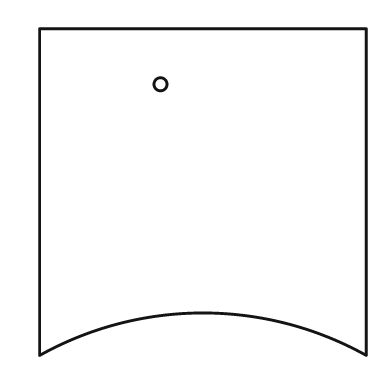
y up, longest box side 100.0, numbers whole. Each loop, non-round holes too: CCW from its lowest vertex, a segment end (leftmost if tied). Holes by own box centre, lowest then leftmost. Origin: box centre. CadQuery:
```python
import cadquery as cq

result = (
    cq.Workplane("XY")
    .moveTo(-50.0, -50.0)
    .threePointArc((0.0, -37.0), (50.0, -50.0))
    .lineTo(50.0, 50.0)
    .lineTo(-50.0, 50.0)
    .close()
    .moveTo(-13.0, 33.0)
    .circle(2.0)
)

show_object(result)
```